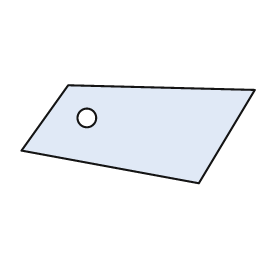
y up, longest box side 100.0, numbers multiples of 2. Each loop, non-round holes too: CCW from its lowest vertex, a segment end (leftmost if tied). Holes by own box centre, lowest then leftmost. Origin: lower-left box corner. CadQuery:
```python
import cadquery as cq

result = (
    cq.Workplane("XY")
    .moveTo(76.0, 0.0)
    .lineTo(100.0, 40.0)
    .lineTo(20.0, 42.0)
    .lineTo(0.0, 14.0)
    .close()
    .moveTo(28.0, 28.0)
    .circle(4.0)
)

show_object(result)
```